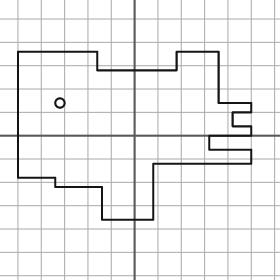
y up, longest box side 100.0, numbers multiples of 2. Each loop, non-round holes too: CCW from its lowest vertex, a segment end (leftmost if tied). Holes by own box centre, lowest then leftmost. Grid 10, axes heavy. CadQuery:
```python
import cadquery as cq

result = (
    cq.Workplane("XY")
    .moveTo(-14.0, -36.0)
    .lineTo(8.0, -36.0)
    .lineTo(8.0, -12.0)
    .lineTo(50.0, -12.0)
    .lineTo(50.0, -6.0)
    .lineTo(32.0, -6.0)
    .lineTo(32.0, 0.0)
    .lineTo(50.0, 0.0)
    .lineTo(50.0, 4.0)
    .lineTo(42.0, 4.0)
    .lineTo(42.0, 10.0)
    .lineTo(50.0, 10.0)
    .lineTo(50.0, 14.0)
    .lineTo(36.0, 14.0)
    .lineTo(36.0, 36.0)
    .lineTo(18.0, 36.0)
    .lineTo(18.0, 28.0)
    .lineTo(-16.0, 28.0)
    .lineTo(-16.0, 36.0)
    .lineTo(-50.0, 36.0)
    .lineTo(-50.0, -18.0)
    .lineTo(-34.0, -18.0)
    .lineTo(-34.0, -22.0)
    .lineTo(-14.0, -22.0)
    .close()
    .moveTo(-32.0, 14.0)
    .circle(2.0)
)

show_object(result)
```